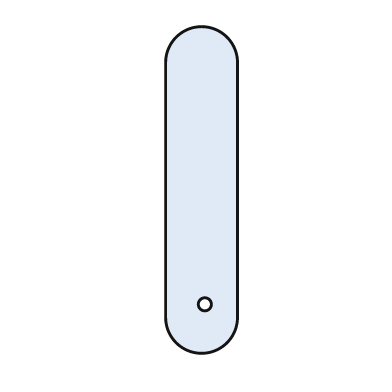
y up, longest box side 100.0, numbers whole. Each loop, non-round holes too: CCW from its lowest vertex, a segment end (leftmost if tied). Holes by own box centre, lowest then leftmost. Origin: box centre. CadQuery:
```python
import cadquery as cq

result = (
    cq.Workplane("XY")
    .moveTo(-11.0, -39.0)
    .threePointArc((0.0, -50.0), (11.0, -39.0))
    .lineTo(11.0, 39.0)
    .threePointArc((0.0, 50.0), (-11.0, 39.0))
    .close()
    .moveTo(1.0, -35.0)
    .circle(2.0)
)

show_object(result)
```